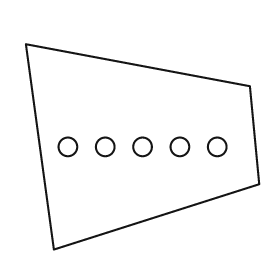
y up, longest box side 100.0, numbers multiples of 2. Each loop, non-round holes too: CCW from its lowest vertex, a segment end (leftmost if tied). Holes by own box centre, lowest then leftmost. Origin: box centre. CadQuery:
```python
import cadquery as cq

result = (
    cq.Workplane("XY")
    .moveTo(-38.0, -44.0)
    .lineTo(50.0, -16.0)
    .lineTo(46.0, 26.0)
    .lineTo(-50.0, 44.0)
    .close()
    .moveTo(-32.0, 0.0)
    .circle(4.0)
    .moveTo(-16.0, 0.0)
    .circle(4.0)
    .moveTo(0.0, 0.0)
    .circle(4.0)
    .moveTo(16.0, 0.0)
    .circle(4.0)
    .moveTo(32.0, 0.0)
    .circle(4.0)
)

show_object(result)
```